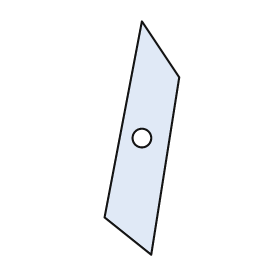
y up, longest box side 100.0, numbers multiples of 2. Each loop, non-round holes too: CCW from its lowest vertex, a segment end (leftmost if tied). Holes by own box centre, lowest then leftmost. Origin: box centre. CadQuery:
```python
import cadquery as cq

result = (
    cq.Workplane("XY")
    .moveTo(4.0, -50.0)
    .lineTo(16.0, 26.0)
    .lineTo(0.0, 50.0)
    .lineTo(-16.0, -34.0)
    .close()
    .moveTo(0.0, 0.0)
    .circle(4.0)
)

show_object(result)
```